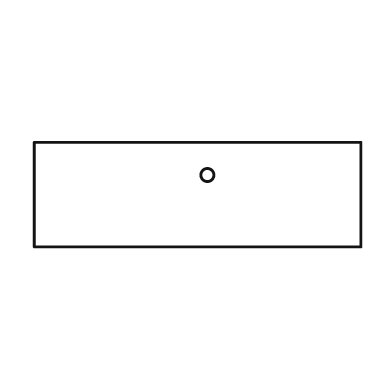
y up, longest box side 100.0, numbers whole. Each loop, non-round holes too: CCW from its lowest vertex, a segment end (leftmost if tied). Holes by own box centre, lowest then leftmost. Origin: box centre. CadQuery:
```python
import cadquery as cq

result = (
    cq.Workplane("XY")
    .moveTo(-50.0, -16.0)
    .lineTo(50.0, -16.0)
    .lineTo(50.0, 16.0)
    .lineTo(-50.0, 16.0)
    .close()
    .moveTo(3.0, 6.0)
    .circle(2.0)
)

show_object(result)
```